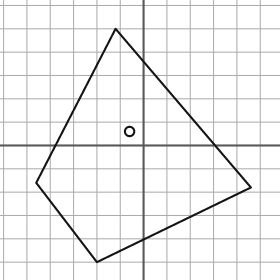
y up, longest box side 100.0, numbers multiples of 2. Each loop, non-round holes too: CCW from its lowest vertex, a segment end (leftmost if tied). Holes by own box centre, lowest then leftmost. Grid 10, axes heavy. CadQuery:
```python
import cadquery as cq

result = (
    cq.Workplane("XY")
    .moveTo(-20.0, -50.0)
    .lineTo(46.0, -18.0)
    .lineTo(-12.0, 50.0)
    .lineTo(-46.0, -16.0)
    .close()
    .moveTo(-6.0, 6.0)
    .circle(2.0)
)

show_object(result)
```